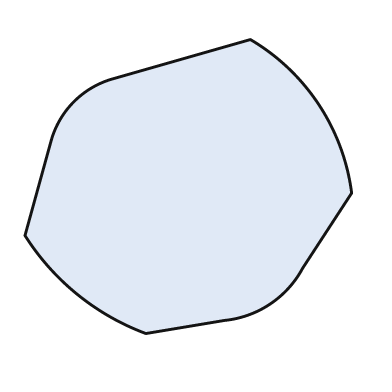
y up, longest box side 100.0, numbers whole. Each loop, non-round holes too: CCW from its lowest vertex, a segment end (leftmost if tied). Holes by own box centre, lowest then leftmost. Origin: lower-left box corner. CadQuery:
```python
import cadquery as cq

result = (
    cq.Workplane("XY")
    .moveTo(37.0, 0.0)
    .lineTo(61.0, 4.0)
    .threePointArc((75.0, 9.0), (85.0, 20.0))
    .lineTo(100.0, 43.0)
    .threePointArc((90.0, 70.0), (69.0, 90.0))
    .lineTo(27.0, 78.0)
    .threePointArc((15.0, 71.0), (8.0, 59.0))
    .lineTo(0.0, 30.0)
    .threePointArc((16.0, 12.0), (37.0, 0.0))
    .close()
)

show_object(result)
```